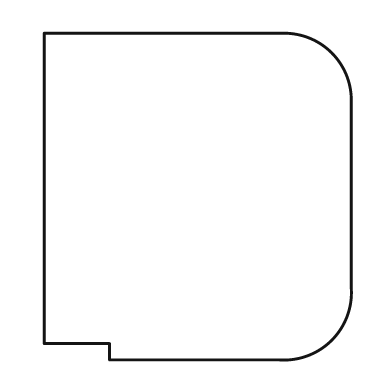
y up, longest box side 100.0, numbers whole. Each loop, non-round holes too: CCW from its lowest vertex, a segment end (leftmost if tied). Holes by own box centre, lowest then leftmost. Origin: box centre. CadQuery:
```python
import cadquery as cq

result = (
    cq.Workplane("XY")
    .moveTo(-27.0, -50.0)
    .lineTo(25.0, -50.0)
    .threePointArc((41.0, -44.0), (47.0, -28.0))
    .lineTo(47.0, 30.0)
    .threePointArc((41.0, 44.0), (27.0, 50.0))
    .lineTo(-47.0, 50.0)
    .lineTo(-47.0, -45.0)
    .lineTo(-27.0, -45.0)
    .close()
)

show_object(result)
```